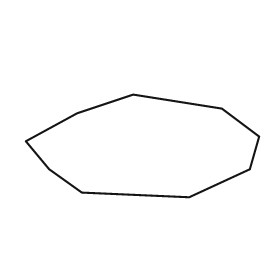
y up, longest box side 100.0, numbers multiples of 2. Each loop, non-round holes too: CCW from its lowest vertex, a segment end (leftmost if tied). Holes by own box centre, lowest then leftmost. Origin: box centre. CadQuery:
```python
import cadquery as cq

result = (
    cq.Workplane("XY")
    .moveTo(20.0, -22.0)
    .lineTo(46.0, -10.0)
    .lineTo(50.0, 4.0)
    .lineTo(34.0, 16.0)
    .lineTo(-4.0, 22.0)
    .lineTo(-28.0, 14.0)
    .lineTo(-50.0, 2.0)
    .lineTo(-40.0, -10.0)
    .lineTo(-26.0, -20.0)
    .close()
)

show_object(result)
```